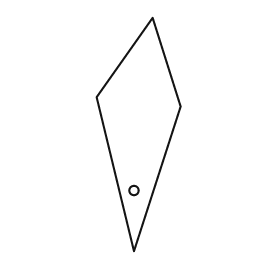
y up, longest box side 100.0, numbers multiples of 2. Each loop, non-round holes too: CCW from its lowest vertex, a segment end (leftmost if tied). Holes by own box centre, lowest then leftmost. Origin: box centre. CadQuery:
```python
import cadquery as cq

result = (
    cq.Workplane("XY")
    .moveTo(-2.0, -50.0)
    .lineTo(18.0, 12.0)
    .lineTo(6.0, 50.0)
    .lineTo(-18.0, 16.0)
    .close()
    .moveTo(-2.0, -24.0)
    .circle(2.0)
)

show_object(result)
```